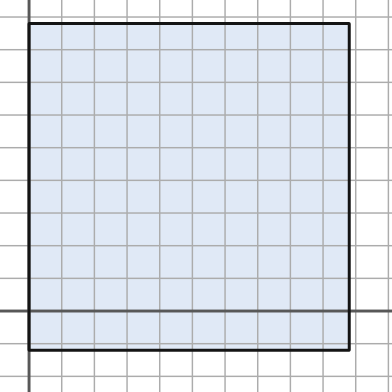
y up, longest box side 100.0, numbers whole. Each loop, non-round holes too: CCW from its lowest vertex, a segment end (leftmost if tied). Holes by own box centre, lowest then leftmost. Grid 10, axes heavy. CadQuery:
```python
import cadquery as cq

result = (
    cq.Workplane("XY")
    .moveTo(0.0, -12.0)
    .lineTo(98.0, -12.0)
    .lineTo(98.0, 88.0)
    .lineTo(0.0, 88.0)
    .close()
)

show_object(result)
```